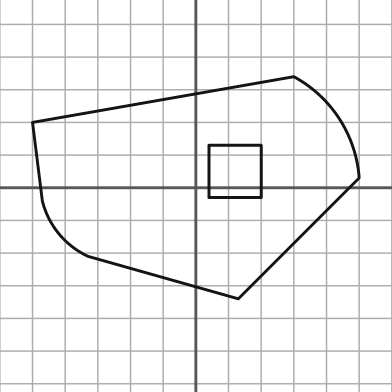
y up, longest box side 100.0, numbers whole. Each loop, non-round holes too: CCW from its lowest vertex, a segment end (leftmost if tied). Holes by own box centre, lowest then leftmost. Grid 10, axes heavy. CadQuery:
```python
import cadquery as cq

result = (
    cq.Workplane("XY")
    .moveTo(13.0, -34.0)
    .lineTo(50.0, 3.0)
    .threePointArc((44.0, 21.0), (30.0, 34.0))
    .lineTo(-50.0, 20.0)
    .lineTo(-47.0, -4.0)
    .threePointArc((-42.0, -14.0), (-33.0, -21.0))
    .close()
    .moveTo(4.0, -3.0)
    .lineTo(20.0, -3.0)
    .lineTo(20.0, 13.0)
    .lineTo(4.0, 13.0)
    .close()
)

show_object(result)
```